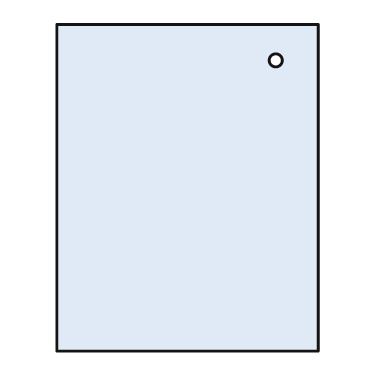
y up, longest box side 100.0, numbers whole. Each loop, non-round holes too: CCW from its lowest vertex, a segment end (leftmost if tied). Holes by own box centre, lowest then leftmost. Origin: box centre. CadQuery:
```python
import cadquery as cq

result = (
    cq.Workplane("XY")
    .moveTo(-40.0, -50.0)
    .lineTo(40.0, -50.0)
    .lineTo(40.0, 50.0)
    .lineTo(-40.0, 50.0)
    .close()
    .moveTo(27.0, 39.0)
    .circle(2.0)
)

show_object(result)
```